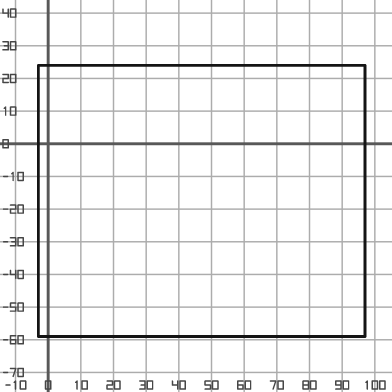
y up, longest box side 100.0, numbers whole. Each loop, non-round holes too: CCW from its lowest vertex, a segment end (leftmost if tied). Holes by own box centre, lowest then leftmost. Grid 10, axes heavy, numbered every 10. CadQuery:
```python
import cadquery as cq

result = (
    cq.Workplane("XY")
    .moveTo(-3.0, -59.0)
    .lineTo(97.0, -59.0)
    .lineTo(97.0, 24.0)
    .lineTo(-3.0, 24.0)
    .close()
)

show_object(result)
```